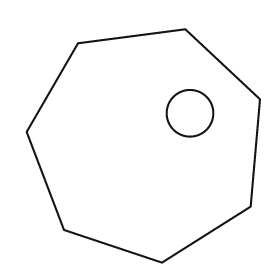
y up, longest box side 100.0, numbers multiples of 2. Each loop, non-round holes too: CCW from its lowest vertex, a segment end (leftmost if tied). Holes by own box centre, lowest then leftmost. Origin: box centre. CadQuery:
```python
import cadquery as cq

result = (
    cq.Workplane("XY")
    .moveTo(8.0, -50.0)
    .lineTo(46.0, -26.0)
    .lineTo(50.0, 20.0)
    .lineTo(18.0, 50.0)
    .lineTo(-28.0, 44.0)
    .lineTo(-50.0, 6.0)
    .lineTo(-34.0, -36.0)
    .close()
    .moveTo(20.0, 14.0)
    .circle(10.0)
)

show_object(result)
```